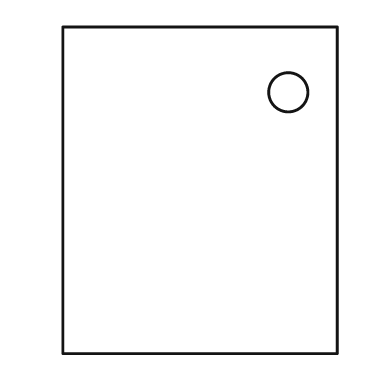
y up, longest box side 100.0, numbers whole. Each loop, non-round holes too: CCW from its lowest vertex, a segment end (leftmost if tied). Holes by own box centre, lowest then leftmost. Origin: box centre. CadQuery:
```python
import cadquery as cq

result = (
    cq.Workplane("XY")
    .moveTo(-42.0, -50.0)
    .lineTo(42.0, -50.0)
    .lineTo(42.0, 50.0)
    .lineTo(-42.0, 50.0)
    .close()
    .moveTo(27.0, 30.0)
    .circle(6.0)
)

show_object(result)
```